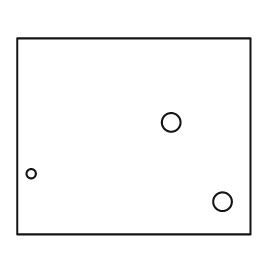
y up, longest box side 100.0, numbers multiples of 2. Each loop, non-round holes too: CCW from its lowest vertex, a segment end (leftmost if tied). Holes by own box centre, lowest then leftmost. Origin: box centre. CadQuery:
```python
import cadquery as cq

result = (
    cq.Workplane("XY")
    .moveTo(-50.0, -42.0)
    .lineTo(50.0, -42.0)
    .lineTo(50.0, 42.0)
    .lineTo(-50.0, 42.0)
    .close()
    .moveTo(38.0, -28.0)
    .circle(4.0)
    .moveTo(-44.0, -16.0)
    .circle(2.0)
    .moveTo(16.0, 6.0)
    .circle(4.0)
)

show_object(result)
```